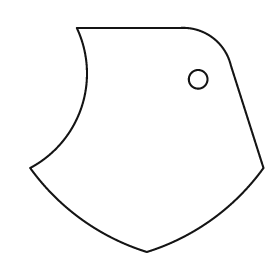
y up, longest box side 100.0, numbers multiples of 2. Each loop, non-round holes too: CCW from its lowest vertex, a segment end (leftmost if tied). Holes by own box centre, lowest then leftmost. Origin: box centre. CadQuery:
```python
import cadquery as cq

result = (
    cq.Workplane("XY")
    .moveTo(0.0, -48.0)
    .threePointArc((28.0, -34.0), (50.0, -12.0))
    .lineTo(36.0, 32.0)
    .threePointArc((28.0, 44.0), (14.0, 48.0))
    .lineTo(-30.0, 48.0)
    .threePointArc((-28.0, 14.0), (-50.0, -12.0))
    .threePointArc((-28.0, -34.0), (0.0, -48.0))
    .close()
    .moveTo(22.0, 26.0)
    .circle(4.0)
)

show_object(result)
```